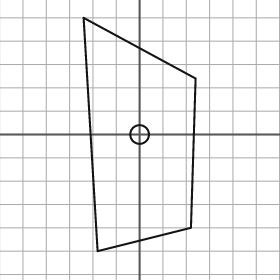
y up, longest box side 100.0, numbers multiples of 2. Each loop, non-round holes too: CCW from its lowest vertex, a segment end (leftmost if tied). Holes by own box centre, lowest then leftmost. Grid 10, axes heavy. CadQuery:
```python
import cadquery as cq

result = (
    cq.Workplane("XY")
    .moveTo(-18.0, -50.0)
    .lineTo(22.0, -40.0)
    .lineTo(24.0, 24.0)
    .lineTo(-24.0, 50.0)
    .close()
    .moveTo(0.0, 0.0)
    .circle(4.0)
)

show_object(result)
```